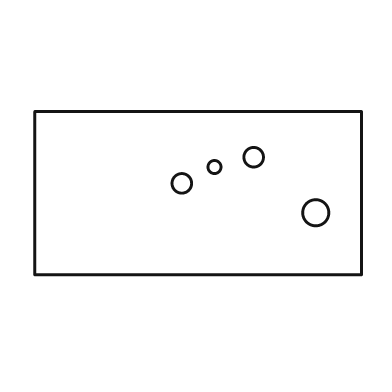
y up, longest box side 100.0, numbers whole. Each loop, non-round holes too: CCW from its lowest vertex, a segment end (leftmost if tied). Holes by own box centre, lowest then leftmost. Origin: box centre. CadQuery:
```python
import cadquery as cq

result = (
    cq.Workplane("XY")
    .moveTo(-50.0, -25.0)
    .lineTo(50.0, -25.0)
    .lineTo(50.0, 25.0)
    .lineTo(-50.0, 25.0)
    .close()
    .moveTo(36.0, -6.0)
    .circle(4.0)
    .moveTo(-5.0, 3.0)
    .circle(3.0)
    .moveTo(5.0, 8.0)
    .circle(2.0)
    .moveTo(17.0, 11.0)
    .circle(3.0)
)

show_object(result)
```